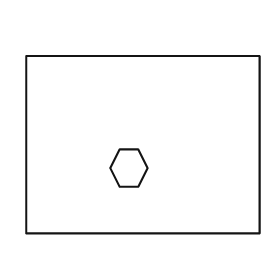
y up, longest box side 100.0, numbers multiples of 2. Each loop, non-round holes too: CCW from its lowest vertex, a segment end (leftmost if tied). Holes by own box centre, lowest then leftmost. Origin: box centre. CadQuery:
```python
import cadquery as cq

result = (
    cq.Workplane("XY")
    .moveTo(-50.0, -38.0)
    .lineTo(50.0, -38.0)
    .lineTo(50.0, 38.0)
    .lineTo(-50.0, 38.0)
    .close()
    .moveTo(-10.0, -18.0)
    .lineTo(-2.0, -18.0)
    .lineTo(2.0, -10.0)
    .lineTo(-2.0, -2.0)
    .lineTo(-10.0, -2.0)
    .lineTo(-14.0, -10.0)
    .close()
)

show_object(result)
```